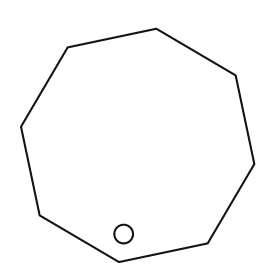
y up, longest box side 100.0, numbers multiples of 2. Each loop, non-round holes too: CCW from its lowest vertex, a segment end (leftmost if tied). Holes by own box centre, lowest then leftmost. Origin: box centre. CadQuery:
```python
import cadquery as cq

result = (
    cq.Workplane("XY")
    .moveTo(-8.0, -50.0)
    .lineTo(30.0, -42.0)
    .lineTo(50.0, -8.0)
    .lineTo(42.0, 30.0)
    .lineTo(8.0, 50.0)
    .lineTo(-30.0, 42.0)
    .lineTo(-50.0, 8.0)
    .lineTo(-42.0, -30.0)
    .close()
    .moveTo(-6.0, -38.0)
    .circle(4.0)
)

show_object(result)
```